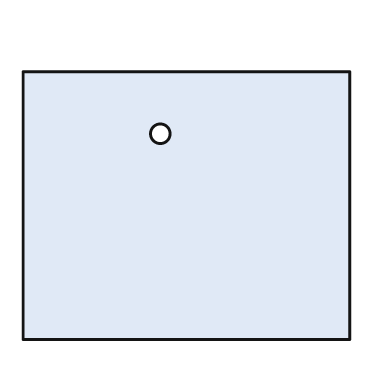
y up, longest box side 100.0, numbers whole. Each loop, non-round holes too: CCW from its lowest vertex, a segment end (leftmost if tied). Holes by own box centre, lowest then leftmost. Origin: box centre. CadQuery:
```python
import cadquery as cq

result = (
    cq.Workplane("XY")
    .moveTo(-50.0, -41.0)
    .lineTo(50.0, -41.0)
    .lineTo(50.0, 41.0)
    .lineTo(-50.0, 41.0)
    .close()
    .moveTo(-8.0, 22.0)
    .circle(3.0)
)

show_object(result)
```